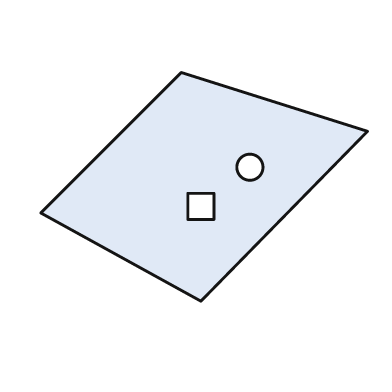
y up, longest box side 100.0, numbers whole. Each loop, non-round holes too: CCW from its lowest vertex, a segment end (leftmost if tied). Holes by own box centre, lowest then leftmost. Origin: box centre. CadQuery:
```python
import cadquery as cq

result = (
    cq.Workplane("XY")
    .moveTo(-1.0, -35.0)
    .lineTo(50.0, 17.0)
    .lineTo(-7.0, 35.0)
    .lineTo(-50.0, -8.0)
    .close()
    .moveTo(-5.0, -10.0)
    .lineTo(3.0, -10.0)
    .lineTo(3.0, -2.0)
    .lineTo(-5.0, -2.0)
    .close()
    .moveTo(14.0, 6.0)
    .circle(4.0)
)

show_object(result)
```